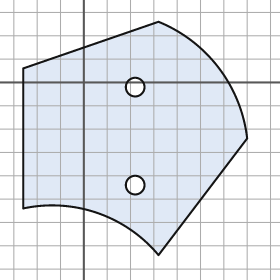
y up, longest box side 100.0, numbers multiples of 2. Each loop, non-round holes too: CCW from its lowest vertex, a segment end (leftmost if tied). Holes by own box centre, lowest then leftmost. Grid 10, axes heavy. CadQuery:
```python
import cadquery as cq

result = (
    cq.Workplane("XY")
    .moveTo(32.0, -74.0)
    .lineTo(70.0, -24.0)
    .threePointArc((58.0, 6.0), (32.0, 26.0))
    .lineTo(-26.0, 6.0)
    .lineTo(-26.0, -54.0)
    .threePointArc((6.0, -56.0), (32.0, -74.0))
    .close()
    .moveTo(22.0, -44.0)
    .circle(4.0)
    .moveTo(22.0, -2.0)
    .circle(4.0)
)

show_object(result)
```